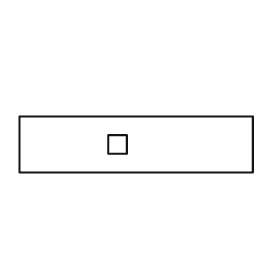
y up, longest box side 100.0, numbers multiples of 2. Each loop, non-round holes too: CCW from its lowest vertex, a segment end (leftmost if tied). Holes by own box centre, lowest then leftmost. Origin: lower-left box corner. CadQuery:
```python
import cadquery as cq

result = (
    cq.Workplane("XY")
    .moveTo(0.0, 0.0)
    .lineTo(100.0, 0.0)
    .lineTo(100.0, 24.0)
    .lineTo(0.0, 24.0)
    .close()
    .moveTo(38.0, 8.0)
    .lineTo(46.0, 8.0)
    .lineTo(46.0, 16.0)
    .lineTo(38.0, 16.0)
    .close()
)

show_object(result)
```